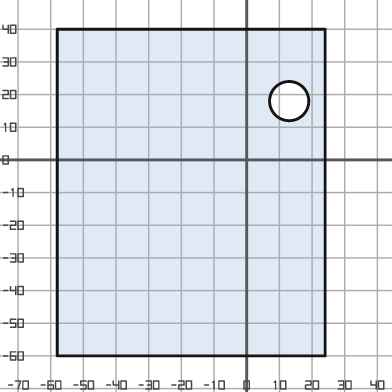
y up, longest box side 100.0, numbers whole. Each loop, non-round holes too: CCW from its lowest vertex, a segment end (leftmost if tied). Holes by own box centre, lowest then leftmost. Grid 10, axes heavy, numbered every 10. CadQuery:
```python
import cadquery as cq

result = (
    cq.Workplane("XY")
    .moveTo(-58.0, -60.0)
    .lineTo(24.0, -60.0)
    .lineTo(24.0, 40.0)
    .lineTo(-58.0, 40.0)
    .close()
    .moveTo(13.0, 18.0)
    .circle(6.0)
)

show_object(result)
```